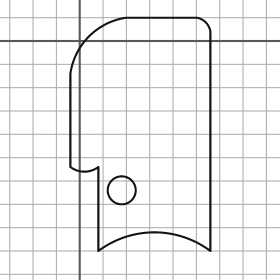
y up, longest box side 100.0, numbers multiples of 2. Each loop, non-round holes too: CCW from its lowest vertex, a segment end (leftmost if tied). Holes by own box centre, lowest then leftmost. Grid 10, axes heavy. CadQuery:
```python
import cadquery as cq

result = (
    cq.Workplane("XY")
    .moveTo(8.0, -90.0)
    .threePointArc((32.0, -82.0), (56.0, -90.0))
    .lineTo(56.0, 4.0)
    .threePointArc((54.0, 8.0), (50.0, 10.0))
    .lineTo(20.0, 10.0)
    .threePointArc((4.0, 2.0), (-4.0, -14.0))
    .lineTo(-4.0, -54.0)
    .threePointArc((2.0, -56.0), (8.0, -54.0))
    .close()
    .moveTo(18.0, -64.0)
    .circle(6.0)
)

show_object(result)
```